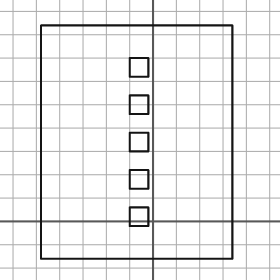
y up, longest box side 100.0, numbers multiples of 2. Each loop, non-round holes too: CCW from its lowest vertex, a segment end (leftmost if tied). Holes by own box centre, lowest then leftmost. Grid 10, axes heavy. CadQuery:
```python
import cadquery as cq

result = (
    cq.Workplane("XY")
    .moveTo(-48.0, -16.0)
    .lineTo(34.0, -16.0)
    .lineTo(34.0, 84.0)
    .lineTo(-48.0, 84.0)
    .close()
    .moveTo(-10.0, -2.0)
    .lineTo(-2.0, -2.0)
    .lineTo(-2.0, 6.0)
    .lineTo(-10.0, 6.0)
    .close()
    .moveTo(-10.0, 14.0)
    .lineTo(-2.0, 14.0)
    .lineTo(-2.0, 22.0)
    .lineTo(-10.0, 22.0)
    .close()
    .moveTo(-10.0, 30.0)
    .lineTo(-2.0, 30.0)
    .lineTo(-2.0, 38.0)
    .lineTo(-10.0, 38.0)
    .close()
    .moveTo(-10.0, 46.0)
    .lineTo(-2.0, 46.0)
    .lineTo(-2.0, 54.0)
    .lineTo(-10.0, 54.0)
    .close()
    .moveTo(-10.0, 62.0)
    .lineTo(-2.0, 62.0)
    .lineTo(-2.0, 70.0)
    .lineTo(-10.0, 70.0)
    .close()
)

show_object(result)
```